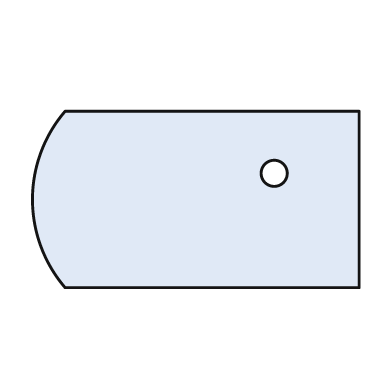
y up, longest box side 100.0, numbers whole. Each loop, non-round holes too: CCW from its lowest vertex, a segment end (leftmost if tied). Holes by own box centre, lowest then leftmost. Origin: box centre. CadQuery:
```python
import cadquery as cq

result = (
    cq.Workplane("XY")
    .moveTo(-40.0, -27.0)
    .lineTo(50.0, -27.0)
    .lineTo(50.0, 27.0)
    .lineTo(-40.0, 27.0)
    .threePointArc((-50.0, 0.0), (-40.0, -27.0))
    .close()
    .moveTo(24.0, 8.0)
    .circle(4.0)
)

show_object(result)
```